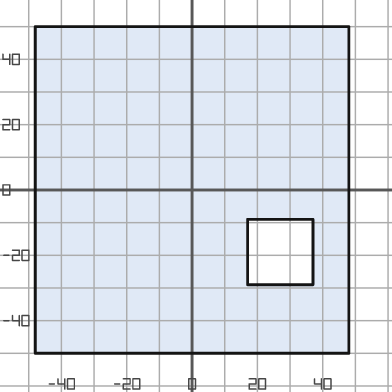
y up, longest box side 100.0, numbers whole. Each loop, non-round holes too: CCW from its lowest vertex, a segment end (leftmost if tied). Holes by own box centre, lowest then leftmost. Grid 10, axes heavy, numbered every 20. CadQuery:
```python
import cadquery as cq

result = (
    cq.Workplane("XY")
    .moveTo(-48.0, -50.0)
    .lineTo(48.0, -50.0)
    .lineTo(48.0, 50.0)
    .lineTo(-48.0, 50.0)
    .close()
    .moveTo(17.0, -29.0)
    .lineTo(37.0, -29.0)
    .lineTo(37.0, -9.0)
    .lineTo(17.0, -9.0)
    .close()
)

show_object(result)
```